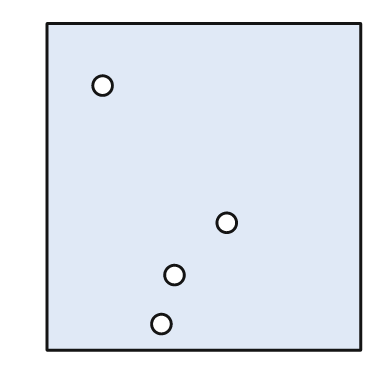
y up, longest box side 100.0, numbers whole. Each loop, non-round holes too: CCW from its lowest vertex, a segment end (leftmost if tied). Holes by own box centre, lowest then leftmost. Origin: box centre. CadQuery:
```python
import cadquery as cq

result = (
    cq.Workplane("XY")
    .moveTo(-48.0, -50.0)
    .lineTo(48.0, -50.0)
    .lineTo(48.0, 50.0)
    .lineTo(-48.0, 50.0)
    .close()
    .moveTo(-13.0, -42.0)
    .circle(3.0)
    .moveTo(-9.0, -27.0)
    .circle(3.0)
    .moveTo(7.0, -11.0)
    .circle(3.0)
    .moveTo(-31.0, 31.0)
    .circle(3.0)
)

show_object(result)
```